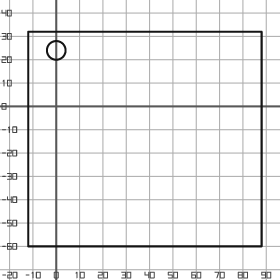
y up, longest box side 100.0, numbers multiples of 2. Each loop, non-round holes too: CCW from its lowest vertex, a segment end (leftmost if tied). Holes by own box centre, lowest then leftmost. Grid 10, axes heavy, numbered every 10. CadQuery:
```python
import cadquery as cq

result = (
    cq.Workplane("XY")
    .moveTo(-12.0, -60.0)
    .lineTo(88.0, -60.0)
    .lineTo(88.0, 32.0)
    .lineTo(-12.0, 32.0)
    .close()
    .moveTo(0.0, 24.0)
    .circle(4.0)
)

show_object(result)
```